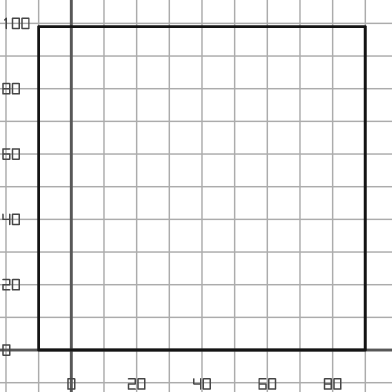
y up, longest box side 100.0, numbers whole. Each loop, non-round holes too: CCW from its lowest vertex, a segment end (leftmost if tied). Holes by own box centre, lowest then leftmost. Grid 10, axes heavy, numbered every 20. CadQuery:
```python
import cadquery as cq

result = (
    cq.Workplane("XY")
    .moveTo(-10.0, 0.0)
    .lineTo(90.0, 0.0)
    .lineTo(90.0, 99.0)
    .lineTo(-10.0, 99.0)
    .close()
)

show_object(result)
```